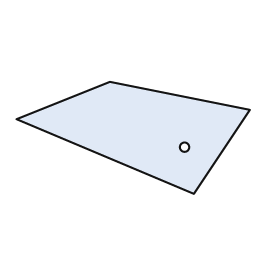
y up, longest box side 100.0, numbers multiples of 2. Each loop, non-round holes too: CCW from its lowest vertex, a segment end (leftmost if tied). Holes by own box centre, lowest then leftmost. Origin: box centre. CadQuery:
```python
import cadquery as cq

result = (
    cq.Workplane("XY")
    .moveTo(26.0, -24.0)
    .lineTo(50.0, 12.0)
    .lineTo(-10.0, 24.0)
    .lineTo(-50.0, 8.0)
    .close()
    .moveTo(22.0, -4.0)
    .circle(2.0)
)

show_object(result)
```